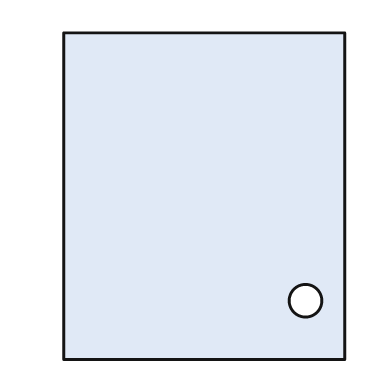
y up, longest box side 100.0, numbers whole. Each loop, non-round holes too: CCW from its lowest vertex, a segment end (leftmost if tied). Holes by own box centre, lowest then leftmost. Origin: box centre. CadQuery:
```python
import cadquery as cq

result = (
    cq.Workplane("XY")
    .moveTo(-43.0, -50.0)
    .lineTo(43.0, -50.0)
    .lineTo(43.0, 50.0)
    .lineTo(-43.0, 50.0)
    .close()
    .moveTo(31.0, -32.0)
    .circle(5.0)
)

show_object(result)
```